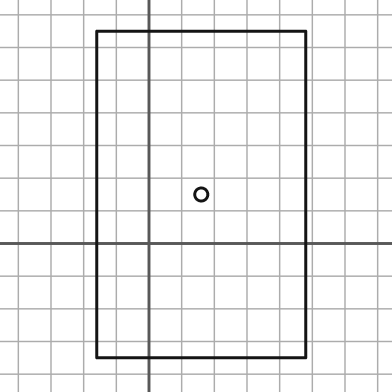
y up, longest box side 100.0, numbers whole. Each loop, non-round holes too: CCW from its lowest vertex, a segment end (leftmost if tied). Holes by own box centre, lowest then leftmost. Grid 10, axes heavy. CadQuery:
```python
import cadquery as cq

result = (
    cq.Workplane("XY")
    .moveTo(-16.0, -35.0)
    .lineTo(48.0, -35.0)
    .lineTo(48.0, 65.0)
    .lineTo(-16.0, 65.0)
    .close()
    .moveTo(16.0, 15.0)
    .circle(2.0)
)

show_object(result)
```